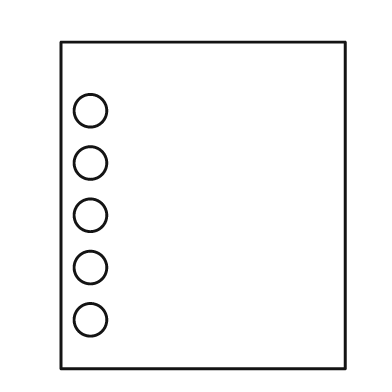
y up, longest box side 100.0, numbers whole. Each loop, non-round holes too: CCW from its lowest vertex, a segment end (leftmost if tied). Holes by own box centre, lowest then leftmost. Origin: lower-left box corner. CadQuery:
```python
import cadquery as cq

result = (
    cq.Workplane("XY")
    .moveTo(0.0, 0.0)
    .lineTo(87.0, 0.0)
    .lineTo(87.0, 100.0)
    .lineTo(0.0, 100.0)
    .close()
    .moveTo(9.0, 15.0)
    .circle(5.0)
    .moveTo(9.0, 31.0)
    .circle(5.0)
    .moveTo(9.0, 47.0)
    .circle(5.0)
    .moveTo(9.0, 63.0)
    .circle(5.0)
    .moveTo(9.0, 79.0)
    .circle(5.0)
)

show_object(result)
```